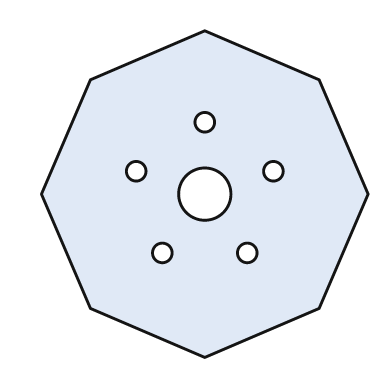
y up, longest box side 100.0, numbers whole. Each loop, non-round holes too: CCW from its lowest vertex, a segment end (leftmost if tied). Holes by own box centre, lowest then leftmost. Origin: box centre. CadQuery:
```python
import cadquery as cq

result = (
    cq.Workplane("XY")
    .moveTo(0.0, -50.0)
    .lineTo(35.0, -35.0)
    .lineTo(50.0, 0.0)
    .lineTo(35.0, 35.0)
    .lineTo(0.0, 50.0)
    .lineTo(-35.0, 35.0)
    .lineTo(-50.0, 0.0)
    .lineTo(-35.0, -35.0)
    .close()
    .moveTo(-13.0, -18.0)
    .circle(3.0)
    .moveTo(13.0, -18.0)
    .circle(3.0)
    .moveTo(0.0, 0.0)
    .circle(8.0)
    .moveTo(-21.0, 7.0)
    .circle(3.0)
    .moveTo(21.0, 7.0)
    .circle(3.0)
    .moveTo(0.0, 22.0)
    .circle(3.0)
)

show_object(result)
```